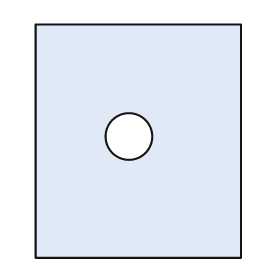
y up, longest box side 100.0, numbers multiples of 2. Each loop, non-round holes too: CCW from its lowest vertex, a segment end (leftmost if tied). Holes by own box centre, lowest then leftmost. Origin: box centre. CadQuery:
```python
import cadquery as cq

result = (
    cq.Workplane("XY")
    .moveTo(-44.0, -50.0)
    .lineTo(44.0, -50.0)
    .lineTo(44.0, 50.0)
    .lineTo(-44.0, 50.0)
    .close()
    .moveTo(-4.0, 2.0)
    .circle(10.0)
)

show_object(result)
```